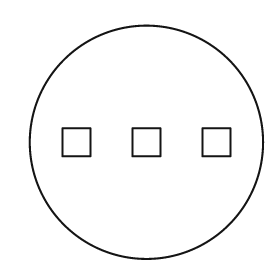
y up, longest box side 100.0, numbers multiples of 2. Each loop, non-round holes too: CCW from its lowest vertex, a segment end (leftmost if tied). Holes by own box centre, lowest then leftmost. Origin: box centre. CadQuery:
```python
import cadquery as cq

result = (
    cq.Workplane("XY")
    .moveTo(0.0, 0.0)
    .circle(50.0)
    .moveTo(-36.0, -6.0)
    .lineTo(-24.0, -6.0)
    .lineTo(-24.0, 6.0)
    .lineTo(-36.0, 6.0)
    .close()
    .moveTo(-6.0, -6.0)
    .lineTo(6.0, -6.0)
    .lineTo(6.0, 6.0)
    .lineTo(-6.0, 6.0)
    .close()
    .moveTo(24.0, -6.0)
    .lineTo(36.0, -6.0)
    .lineTo(36.0, 6.0)
    .lineTo(24.0, 6.0)
    .close()
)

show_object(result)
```